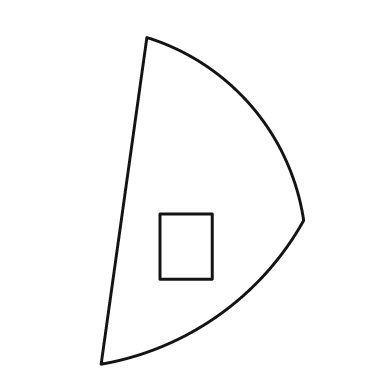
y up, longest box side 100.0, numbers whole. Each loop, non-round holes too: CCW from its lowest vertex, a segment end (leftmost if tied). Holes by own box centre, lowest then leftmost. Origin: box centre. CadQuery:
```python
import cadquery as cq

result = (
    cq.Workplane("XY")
    .moveTo(-31.0, -50.0)
    .threePointArc((5.0, -35.0), (31.0, -6.0))
    .threePointArc((15.0, 29.0), (-17.0, 50.0))
    .close()
    .moveTo(-13.0, -24.0)
    .lineTo(3.0, -24.0)
    .lineTo(3.0, -4.0)
    .lineTo(-13.0, -4.0)
    .close()
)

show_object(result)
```